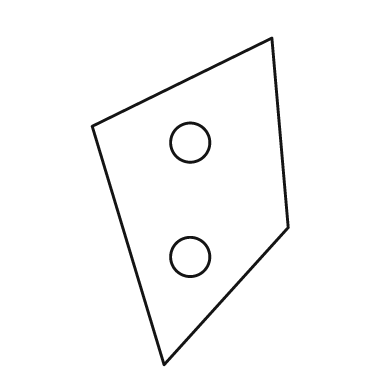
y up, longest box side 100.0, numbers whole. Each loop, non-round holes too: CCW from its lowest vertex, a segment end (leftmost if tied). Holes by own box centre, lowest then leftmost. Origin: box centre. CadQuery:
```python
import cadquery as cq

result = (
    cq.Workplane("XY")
    .moveTo(-8.0, -50.0)
    .lineTo(30.0, -8.0)
    .lineTo(25.0, 50.0)
    .lineTo(-30.0, 23.0)
    .close()
    .moveTo(0.0, -17.0)
    .circle(6.0)
    .moveTo(0.0, 18.0)
    .circle(6.0)
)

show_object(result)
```